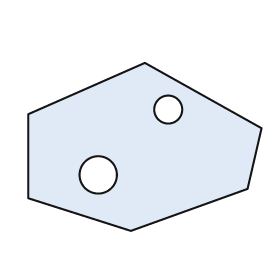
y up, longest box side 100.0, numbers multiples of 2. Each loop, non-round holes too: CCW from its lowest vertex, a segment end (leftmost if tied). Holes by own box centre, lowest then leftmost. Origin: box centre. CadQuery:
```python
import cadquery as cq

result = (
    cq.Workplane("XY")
    .moveTo(-6.0, -36.0)
    .lineTo(44.0, -18.0)
    .lineTo(50.0, 8.0)
    .lineTo(0.0, 36.0)
    .lineTo(-50.0, 14.0)
    .lineTo(-50.0, -22.0)
    .close()
    .moveTo(-20.0, -12.0)
    .circle(8.0)
    .moveTo(10.0, 16.0)
    .circle(6.0)
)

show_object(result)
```